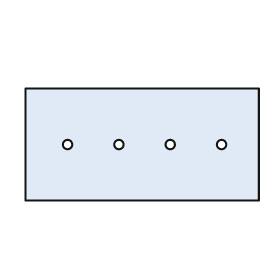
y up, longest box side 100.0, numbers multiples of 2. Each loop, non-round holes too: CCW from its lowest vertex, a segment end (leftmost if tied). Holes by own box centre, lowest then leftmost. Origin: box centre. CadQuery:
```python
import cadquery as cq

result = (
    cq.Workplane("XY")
    .moveTo(-50.0, -24.0)
    .lineTo(50.0, -24.0)
    .lineTo(50.0, 24.0)
    .lineTo(-50.0, 24.0)
    .close()
    .moveTo(-32.0, 0.0)
    .circle(2.0)
    .moveTo(-10.0, 0.0)
    .circle(2.0)
    .moveTo(12.0, 0.0)
    .circle(2.0)
    .moveTo(34.0, 0.0)
    .circle(2.0)
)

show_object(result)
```